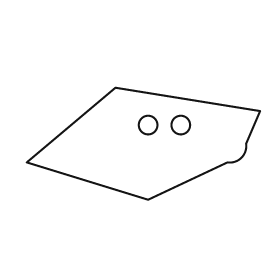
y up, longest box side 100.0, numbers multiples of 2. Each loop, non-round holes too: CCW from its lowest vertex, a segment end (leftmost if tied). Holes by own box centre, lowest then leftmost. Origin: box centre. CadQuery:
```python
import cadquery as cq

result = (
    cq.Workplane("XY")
    .moveTo(2.0, -24.0)
    .lineTo(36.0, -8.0)
    .threePointArc((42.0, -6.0), (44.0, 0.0))
    .lineTo(50.0, 14.0)
    .lineTo(-12.0, 24.0)
    .lineTo(-50.0, -8.0)
    .close()
    .moveTo(2.0, 8.0)
    .circle(4.0)
    .moveTo(16.0, 8.0)
    .circle(4.0)
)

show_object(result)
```